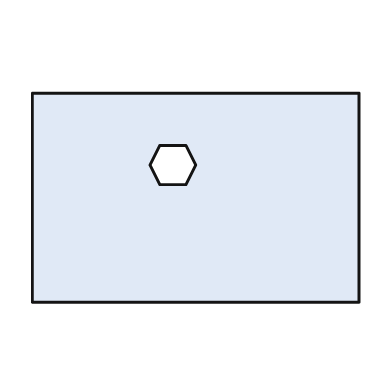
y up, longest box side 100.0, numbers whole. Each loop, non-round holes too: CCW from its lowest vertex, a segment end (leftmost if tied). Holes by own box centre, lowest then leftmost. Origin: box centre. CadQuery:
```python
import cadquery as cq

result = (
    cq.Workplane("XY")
    .moveTo(-50.0, -32.0)
    .lineTo(50.0, -32.0)
    .lineTo(50.0, 32.0)
    .lineTo(-50.0, 32.0)
    .close()
    .moveTo(-11.0, 4.0)
    .lineTo(-3.0, 4.0)
    .lineTo(0.0, 10.0)
    .lineTo(-3.0, 16.0)
    .lineTo(-11.0, 16.0)
    .lineTo(-14.0, 10.0)
    .close()
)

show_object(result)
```